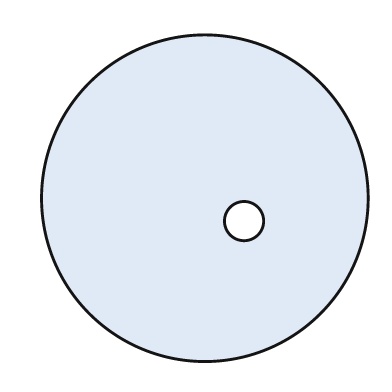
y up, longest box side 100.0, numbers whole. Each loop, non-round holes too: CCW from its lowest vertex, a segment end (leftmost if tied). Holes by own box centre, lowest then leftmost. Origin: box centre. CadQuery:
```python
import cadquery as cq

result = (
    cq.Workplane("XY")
    .moveTo(0.0, 0.0)
    .circle(50.0)
    .moveTo(12.0, -7.0)
    .circle(6.0)
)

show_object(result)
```